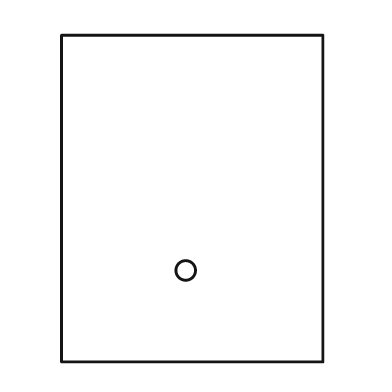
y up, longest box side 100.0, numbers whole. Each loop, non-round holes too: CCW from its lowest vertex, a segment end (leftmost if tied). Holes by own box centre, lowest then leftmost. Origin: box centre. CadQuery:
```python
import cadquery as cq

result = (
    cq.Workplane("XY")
    .moveTo(-40.0, -50.0)
    .lineTo(40.0, -50.0)
    .lineTo(40.0, 50.0)
    .lineTo(-40.0, 50.0)
    .close()
    .moveTo(-2.0, -22.0)
    .circle(3.0)
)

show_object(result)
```